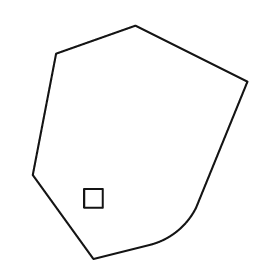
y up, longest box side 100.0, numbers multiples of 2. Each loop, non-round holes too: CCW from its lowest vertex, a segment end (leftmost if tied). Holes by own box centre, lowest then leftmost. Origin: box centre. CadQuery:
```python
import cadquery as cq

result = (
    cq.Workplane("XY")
    .moveTo(-20.0, -50.0)
    .lineTo(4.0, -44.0)
    .threePointArc((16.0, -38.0), (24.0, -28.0))
    .lineTo(46.0, 26.0)
    .lineTo(-2.0, 50.0)
    .lineTo(-36.0, 38.0)
    .lineTo(-46.0, -14.0)
    .close()
    .moveTo(-24.0, -28.0)
    .lineTo(-16.0, -28.0)
    .lineTo(-16.0, -20.0)
    .lineTo(-24.0, -20.0)
    .close()
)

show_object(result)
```